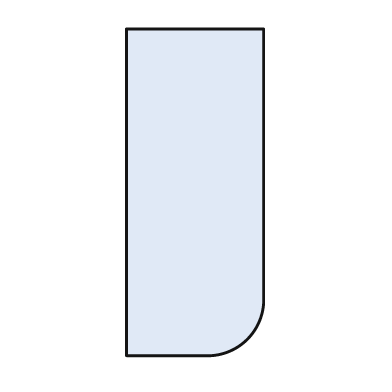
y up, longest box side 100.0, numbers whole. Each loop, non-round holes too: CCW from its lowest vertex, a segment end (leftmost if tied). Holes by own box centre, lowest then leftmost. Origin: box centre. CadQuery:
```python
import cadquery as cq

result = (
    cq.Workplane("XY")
    .moveTo(-21.0, -50.0)
    .lineTo(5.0, -50.0)
    .threePointArc((16.0, -45.0), (21.0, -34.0))
    .lineTo(21.0, 50.0)
    .lineTo(-21.0, 50.0)
    .close()
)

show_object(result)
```